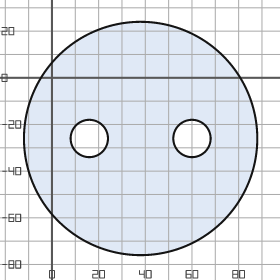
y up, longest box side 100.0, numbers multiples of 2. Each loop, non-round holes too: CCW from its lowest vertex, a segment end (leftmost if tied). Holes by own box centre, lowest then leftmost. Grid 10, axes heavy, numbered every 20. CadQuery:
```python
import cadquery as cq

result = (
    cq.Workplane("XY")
    .moveTo(38.0, -26.0)
    .circle(50.0)
    .moveTo(16.0, -26.0)
    .circle(8.0)
    .moveTo(60.0, -26.0)
    .circle(8.0)
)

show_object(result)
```